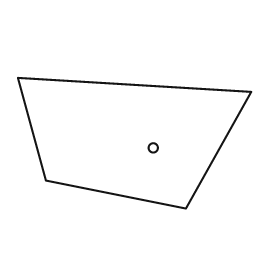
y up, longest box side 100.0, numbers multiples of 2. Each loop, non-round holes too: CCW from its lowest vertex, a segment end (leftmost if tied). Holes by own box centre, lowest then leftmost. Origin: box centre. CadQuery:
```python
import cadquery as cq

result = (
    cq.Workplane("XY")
    .moveTo(22.0, -28.0)
    .lineTo(50.0, 22.0)
    .lineTo(-50.0, 28.0)
    .lineTo(-38.0, -16.0)
    .close()
    .moveTo(8.0, -2.0)
    .circle(2.0)
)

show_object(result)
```